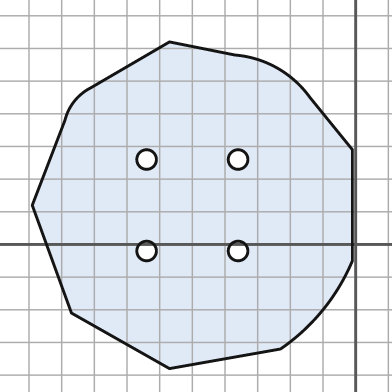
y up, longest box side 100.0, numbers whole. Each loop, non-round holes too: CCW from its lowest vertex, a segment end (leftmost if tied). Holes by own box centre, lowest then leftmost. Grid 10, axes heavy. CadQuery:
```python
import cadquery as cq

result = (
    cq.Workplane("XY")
    .moveTo(-57.0, -38.0)
    .lineTo(-23.0, -32.0)
    .threePointArc((-10.0, -20.0), (-1.0, -5.0))
    .lineTo(-1.0, 29.0)
    .lineTo(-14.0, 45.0)
    .threePointArc((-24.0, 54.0), (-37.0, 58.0))
    .lineTo(-57.0, 62.0)
    .lineTo(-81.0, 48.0)
    .threePointArc((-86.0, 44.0), (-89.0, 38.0))
    .lineTo(-99.0, 12.0)
    .lineTo(-87.0, -21.0)
    .close()
    .moveTo(-64.0, -2.0)
    .circle(3.0)
    .moveTo(-36.0, -2.0)
    .circle(3.0)
    .moveTo(-64.0, 26.0)
    .circle(3.0)
    .moveTo(-36.0, 26.0)
    .circle(3.0)
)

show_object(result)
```